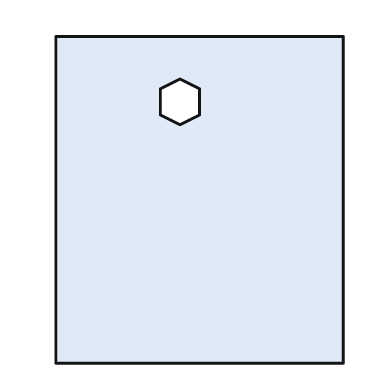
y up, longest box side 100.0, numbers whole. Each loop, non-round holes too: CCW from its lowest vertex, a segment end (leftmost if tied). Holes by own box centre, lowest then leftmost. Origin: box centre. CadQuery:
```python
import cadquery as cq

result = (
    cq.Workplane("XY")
    .moveTo(-44.0, -50.0)
    .lineTo(44.0, -50.0)
    .lineTo(44.0, 50.0)
    .lineTo(-44.0, 50.0)
    .close()
    .moveTo(-6.0, 23.0)
    .lineTo(0.0, 26.0)
    .lineTo(0.0, 34.0)
    .lineTo(-6.0, 37.0)
    .lineTo(-12.0, 34.0)
    .lineTo(-12.0, 26.0)
    .close()
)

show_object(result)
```